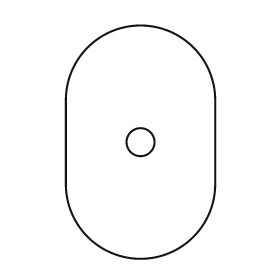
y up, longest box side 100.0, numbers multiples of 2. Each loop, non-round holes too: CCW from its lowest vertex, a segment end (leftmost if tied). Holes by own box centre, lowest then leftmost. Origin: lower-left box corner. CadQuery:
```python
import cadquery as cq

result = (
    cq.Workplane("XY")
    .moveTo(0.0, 32.0)
    .threePointArc((32.0, 0.0), (64.0, 32.0))
    .lineTo(64.0, 68.0)
    .threePointArc((32.0, 100.0), (0.0, 68.0))
    .close()
    .moveTo(32.0, 50.0)
    .circle(6.0)
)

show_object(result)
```